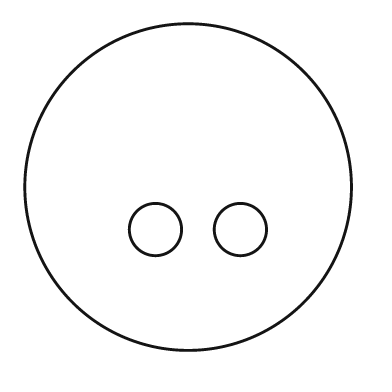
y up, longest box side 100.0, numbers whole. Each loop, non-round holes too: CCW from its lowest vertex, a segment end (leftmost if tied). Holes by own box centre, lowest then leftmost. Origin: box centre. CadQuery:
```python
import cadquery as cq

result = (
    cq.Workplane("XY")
    .moveTo(0.0, 0.0)
    .circle(50.0)
    .moveTo(-10.0, -13.0)
    .circle(8.0)
    .moveTo(16.0, -13.0)
    .circle(8.0)
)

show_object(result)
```